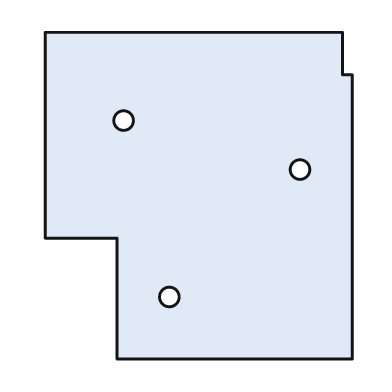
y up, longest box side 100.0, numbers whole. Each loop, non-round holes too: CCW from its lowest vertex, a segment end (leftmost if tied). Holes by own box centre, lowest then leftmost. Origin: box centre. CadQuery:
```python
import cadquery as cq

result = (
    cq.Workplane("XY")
    .moveTo(-25.0, -50.0)
    .lineTo(47.0, -50.0)
    .lineTo(47.0, 37.0)
    .lineTo(44.0, 37.0)
    .lineTo(44.0, 50.0)
    .lineTo(-47.0, 50.0)
    .lineTo(-47.0, -13.0)
    .lineTo(-25.0, -13.0)
    .close()
    .moveTo(-9.0, -31.0)
    .circle(3.0)
    .moveTo(31.0, 8.0)
    .circle(3.0)
    .moveTo(-23.0, 23.0)
    .circle(3.0)
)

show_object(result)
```